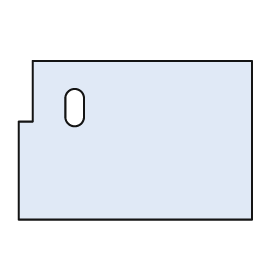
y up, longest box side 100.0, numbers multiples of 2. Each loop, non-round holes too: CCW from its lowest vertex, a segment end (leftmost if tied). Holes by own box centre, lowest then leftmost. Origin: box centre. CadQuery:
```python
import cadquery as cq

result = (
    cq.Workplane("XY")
    .moveTo(-50.0, -34.0)
    .lineTo(50.0, -34.0)
    .lineTo(50.0, 34.0)
    .lineTo(-44.0, 34.0)
    .lineTo(-44.0, 8.0)
    .lineTo(-50.0, 8.0)
    .close()
    .moveTo(-30.0, 10.0)
    .threePointArc((-26.0, 6.0), (-22.0, 10.0))
    .lineTo(-22.0, 18.0)
    .threePointArc((-26.0, 22.0), (-30.0, 18.0))
    .close()
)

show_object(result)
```